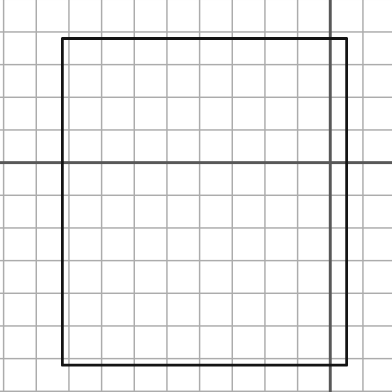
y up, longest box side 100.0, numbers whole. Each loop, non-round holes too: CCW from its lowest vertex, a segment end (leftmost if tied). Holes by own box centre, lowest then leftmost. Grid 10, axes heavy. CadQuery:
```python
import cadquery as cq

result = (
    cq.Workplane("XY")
    .moveTo(-82.0, -62.0)
    .lineTo(5.0, -62.0)
    .lineTo(5.0, 38.0)
    .lineTo(-82.0, 38.0)
    .close()
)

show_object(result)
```